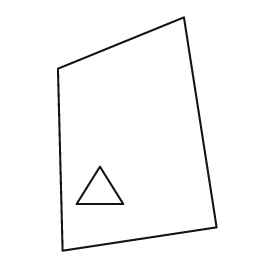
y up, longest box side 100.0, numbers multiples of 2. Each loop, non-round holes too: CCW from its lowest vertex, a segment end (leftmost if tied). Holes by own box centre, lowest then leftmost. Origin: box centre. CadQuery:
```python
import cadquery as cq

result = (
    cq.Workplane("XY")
    .moveTo(-32.0, -50.0)
    .lineTo(34.0, -40.0)
    .lineTo(20.0, 50.0)
    .lineTo(-34.0, 28.0)
    .close()
    .moveTo(-26.0, -30.0)
    .lineTo(-6.0, -30.0)
    .lineTo(-16.0, -14.0)
    .close()
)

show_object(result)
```